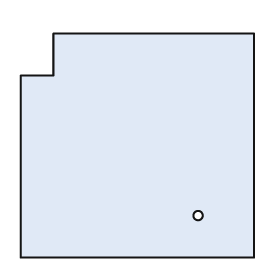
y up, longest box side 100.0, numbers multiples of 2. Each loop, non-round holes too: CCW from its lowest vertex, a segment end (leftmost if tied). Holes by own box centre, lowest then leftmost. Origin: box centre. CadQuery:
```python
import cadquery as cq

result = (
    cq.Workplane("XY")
    .moveTo(-50.0, -48.0)
    .lineTo(50.0, -48.0)
    .lineTo(50.0, 48.0)
    .lineTo(-36.0, 48.0)
    .lineTo(-36.0, 30.0)
    .lineTo(-50.0, 30.0)
    .close()
    .moveTo(26.0, -30.0)
    .circle(2.0)
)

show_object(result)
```